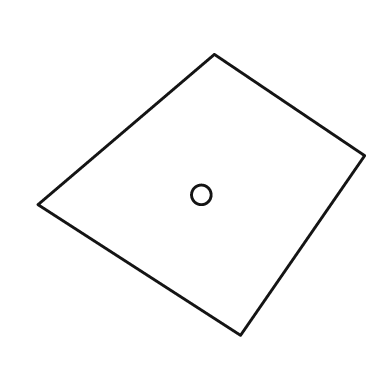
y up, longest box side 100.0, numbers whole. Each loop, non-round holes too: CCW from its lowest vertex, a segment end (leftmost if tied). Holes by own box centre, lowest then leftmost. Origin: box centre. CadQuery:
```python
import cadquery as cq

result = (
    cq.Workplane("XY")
    .moveTo(12.0, -43.0)
    .lineTo(50.0, 12.0)
    .lineTo(4.0, 43.0)
    .lineTo(-50.0, -3.0)
    .close()
    .moveTo(0.0, 0.0)
    .circle(3.0)
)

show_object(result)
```